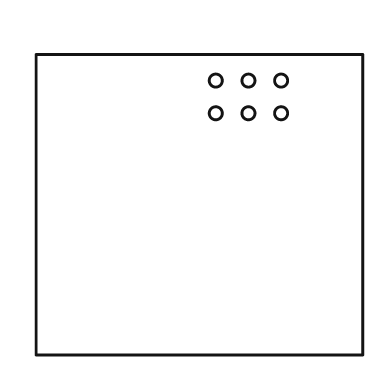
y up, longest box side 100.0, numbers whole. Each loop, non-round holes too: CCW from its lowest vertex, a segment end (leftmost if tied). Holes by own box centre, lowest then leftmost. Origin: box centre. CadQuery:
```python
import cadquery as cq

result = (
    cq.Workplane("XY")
    .moveTo(-50.0, -46.0)
    .lineTo(50.0, -46.0)
    .lineTo(50.0, 46.0)
    .lineTo(-50.0, 46.0)
    .close()
    .moveTo(5.0, 28.0)
    .circle(2.0)
    .moveTo(15.0, 28.0)
    .circle(2.0)
    .moveTo(25.0, 28.0)
    .circle(2.0)
    .moveTo(5.0, 38.0)
    .circle(2.0)
    .moveTo(15.0, 38.0)
    .circle(2.0)
    .moveTo(25.0, 38.0)
    .circle(2.0)
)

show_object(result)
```